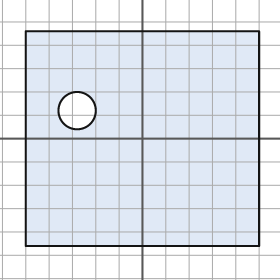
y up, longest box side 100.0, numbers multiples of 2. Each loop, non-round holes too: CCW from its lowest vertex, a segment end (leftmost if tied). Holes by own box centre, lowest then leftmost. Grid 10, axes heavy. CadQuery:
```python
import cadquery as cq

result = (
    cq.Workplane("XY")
    .moveTo(-50.0, -46.0)
    .lineTo(50.0, -46.0)
    .lineTo(50.0, 46.0)
    .lineTo(-50.0, 46.0)
    .close()
    .moveTo(-28.0, 12.0)
    .circle(8.0)
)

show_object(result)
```